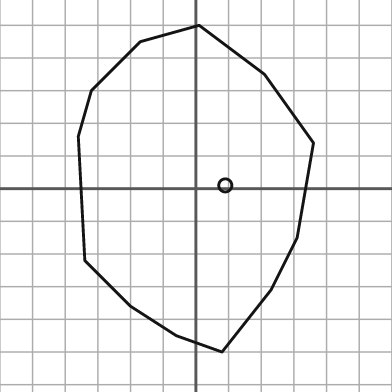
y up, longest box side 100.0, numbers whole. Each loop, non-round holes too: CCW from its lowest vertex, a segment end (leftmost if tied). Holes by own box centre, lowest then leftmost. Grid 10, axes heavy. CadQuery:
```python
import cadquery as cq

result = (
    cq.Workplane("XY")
    .moveTo(8.0, -50.0)
    .lineTo(23.0, -31.0)
    .lineTo(31.0, -15.0)
    .lineTo(36.0, 14.0)
    .lineTo(21.0, 35.0)
    .lineTo(1.0, 50.0)
    .lineTo(-17.0, 45.0)
    .lineTo(-32.0, 30.0)
    .lineTo(-36.0, 16.0)
    .lineTo(-34.0, -22.0)
    .lineTo(-20.0, -36.0)
    .lineTo(-6.0, -45.0)
    .close()
    .moveTo(9.0, 1.0)
    .circle(2.0)
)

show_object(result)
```